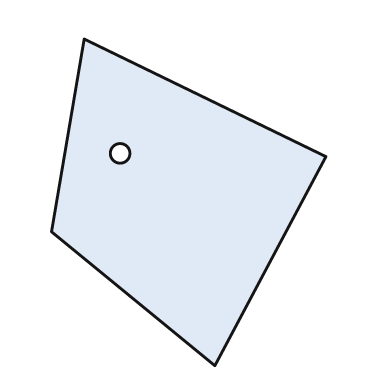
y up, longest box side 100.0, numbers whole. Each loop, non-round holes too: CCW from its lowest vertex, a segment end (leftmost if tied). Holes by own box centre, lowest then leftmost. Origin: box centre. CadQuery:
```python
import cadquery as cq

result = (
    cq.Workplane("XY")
    .moveTo(8.0, -50.0)
    .lineTo(42.0, 14.0)
    .lineTo(-32.0, 50.0)
    .lineTo(-42.0, -9.0)
    .close()
    .moveTo(-21.0, 15.0)
    .circle(3.0)
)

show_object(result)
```